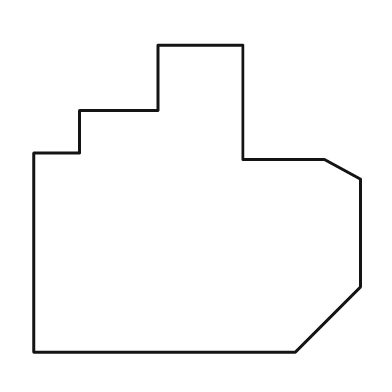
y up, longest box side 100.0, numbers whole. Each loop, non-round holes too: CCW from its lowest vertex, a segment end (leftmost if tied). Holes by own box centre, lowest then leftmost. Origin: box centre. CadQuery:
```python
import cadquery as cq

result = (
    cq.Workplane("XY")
    .moveTo(-50.0, -47.0)
    .lineTo(30.0, -47.0)
    .lineTo(50.0, -27.0)
    .lineTo(50.0, 6.0)
    .lineTo(39.0, 12.0)
    .lineTo(14.0, 12.0)
    .lineTo(14.0, 47.0)
    .lineTo(-12.0, 47.0)
    .lineTo(-12.0, 27.0)
    .lineTo(-36.0, 27.0)
    .lineTo(-36.0, 14.0)
    .lineTo(-50.0, 14.0)
    .close()
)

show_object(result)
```